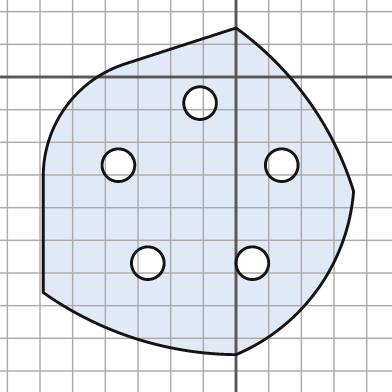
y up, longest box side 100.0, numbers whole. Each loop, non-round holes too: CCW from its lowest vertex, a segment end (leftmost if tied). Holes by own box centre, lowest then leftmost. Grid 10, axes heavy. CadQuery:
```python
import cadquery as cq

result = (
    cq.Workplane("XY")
    .moveTo(0.0, -85.0)
    .threePointArc((25.0, -65.0), (36.0, -35.0))
    .threePointArc((22.0, -7.0), (0.0, 15.0))
    .lineTo(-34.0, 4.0)
    .threePointArc((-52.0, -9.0), (-59.0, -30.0))
    .lineTo(-59.0, -66.0)
    .threePointArc((-31.0, -80.0), (0.0, -85.0))
    .close()
    .moveTo(-27.0, -57.0)
    .circle(5.0)
    .moveTo(5.0, -57.0)
    .circle(5.0)
    .moveTo(-36.0, -27.0)
    .circle(5.0)
    .moveTo(14.0, -27.0)
    .circle(5.0)
    .moveTo(-11.0, -8.0)
    .circle(5.0)
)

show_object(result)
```